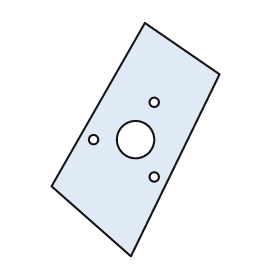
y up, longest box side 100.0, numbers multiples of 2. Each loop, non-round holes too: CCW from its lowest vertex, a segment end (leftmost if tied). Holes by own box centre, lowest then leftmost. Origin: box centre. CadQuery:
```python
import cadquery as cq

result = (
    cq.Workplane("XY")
    .moveTo(-2.0, -50.0)
    .lineTo(36.0, 28.0)
    .lineTo(4.0, 50.0)
    .lineTo(-36.0, -20.0)
    .close()
    .moveTo(8.0, -16.0)
    .circle(2.0)
    .moveTo(-18.0, 0.0)
    .circle(2.0)
    .moveTo(0.0, 0.0)
    .circle(8.0)
    .moveTo(8.0, 16.0)
    .circle(2.0)
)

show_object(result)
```